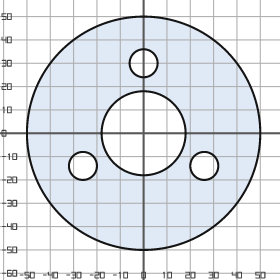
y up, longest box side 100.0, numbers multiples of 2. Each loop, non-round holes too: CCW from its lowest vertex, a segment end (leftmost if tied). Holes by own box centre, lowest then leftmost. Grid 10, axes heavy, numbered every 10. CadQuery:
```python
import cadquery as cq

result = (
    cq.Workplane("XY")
    .moveTo(0.0, 0.0)
    .circle(50.0)
    .moveTo(-26.0, -14.0)
    .circle(6.0)
    .moveTo(26.0, -14.0)
    .circle(6.0)
    .moveTo(0.0, 0.0)
    .circle(18.0)
    .moveTo(0.0, 30.0)
    .circle(6.0)
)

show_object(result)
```